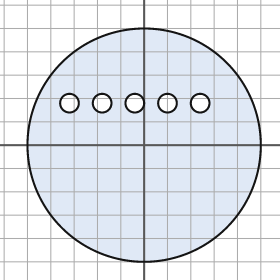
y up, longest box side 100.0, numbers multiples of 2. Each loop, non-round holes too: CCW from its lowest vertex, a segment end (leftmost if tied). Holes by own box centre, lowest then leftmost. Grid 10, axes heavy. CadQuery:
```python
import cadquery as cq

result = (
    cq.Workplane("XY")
    .moveTo(0.0, 0.0)
    .circle(50.0)
    .moveTo(-32.0, 18.0)
    .circle(4.0)
    .moveTo(-18.0, 18.0)
    .circle(4.0)
    .moveTo(-4.0, 18.0)
    .circle(4.0)
    .moveTo(10.0, 18.0)
    .circle(4.0)
    .moveTo(24.0, 18.0)
    .circle(4.0)
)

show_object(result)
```